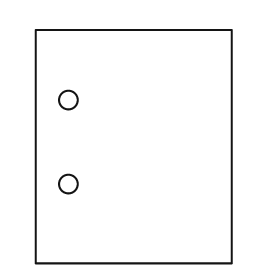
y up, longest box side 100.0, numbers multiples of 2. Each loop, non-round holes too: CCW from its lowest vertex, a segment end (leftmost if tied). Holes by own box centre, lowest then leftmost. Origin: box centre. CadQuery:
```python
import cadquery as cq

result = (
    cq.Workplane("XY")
    .moveTo(-42.0, -50.0)
    .lineTo(42.0, -50.0)
    .lineTo(42.0, 50.0)
    .lineTo(-42.0, 50.0)
    .close()
    .moveTo(-28.0, -16.0)
    .circle(4.0)
    .moveTo(-28.0, 20.0)
    .circle(4.0)
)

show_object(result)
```